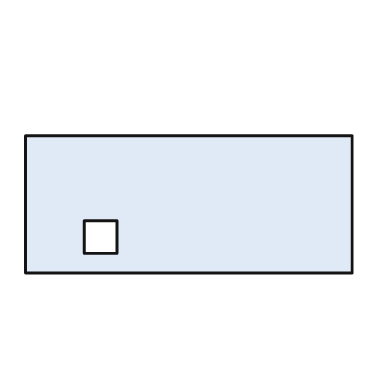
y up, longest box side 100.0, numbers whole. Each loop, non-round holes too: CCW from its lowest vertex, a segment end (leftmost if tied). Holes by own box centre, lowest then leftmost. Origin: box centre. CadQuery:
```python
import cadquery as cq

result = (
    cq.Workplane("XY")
    .moveTo(-50.0, -21.0)
    .lineTo(50.0, -21.0)
    .lineTo(50.0, 21.0)
    .lineTo(-50.0, 21.0)
    .close()
    .moveTo(-32.0, -15.0)
    .lineTo(-22.0, -15.0)
    .lineTo(-22.0, -5.0)
    .lineTo(-32.0, -5.0)
    .close()
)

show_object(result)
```